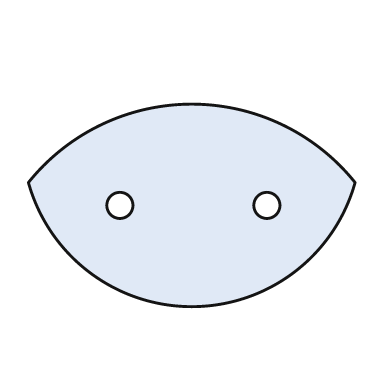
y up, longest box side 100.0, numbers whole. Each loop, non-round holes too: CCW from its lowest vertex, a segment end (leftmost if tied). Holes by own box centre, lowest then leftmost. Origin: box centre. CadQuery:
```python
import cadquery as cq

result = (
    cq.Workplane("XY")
    .moveTo(-50.0, 7.0)
    .threePointArc((0.0, -31.0), (50.0, 7.0))
    .threePointArc((0.0, 31.0), (-50.0, 7.0))
    .close()
    .moveTo(-22.0, 0.0)
    .circle(4.0)
    .moveTo(23.0, 0.0)
    .circle(4.0)
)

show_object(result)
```